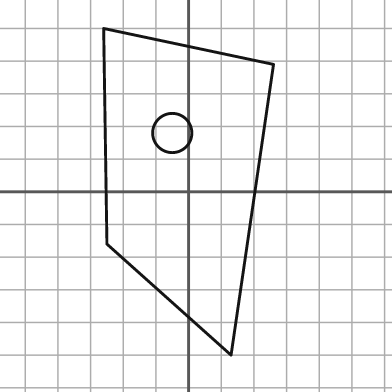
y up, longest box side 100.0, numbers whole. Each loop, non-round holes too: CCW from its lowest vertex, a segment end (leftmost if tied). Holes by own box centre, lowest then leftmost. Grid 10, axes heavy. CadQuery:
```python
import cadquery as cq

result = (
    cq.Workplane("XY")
    .moveTo(13.0, -50.0)
    .lineTo(26.0, 39.0)
    .lineTo(-26.0, 50.0)
    .lineTo(-25.0, -16.0)
    .close()
    .moveTo(-5.0, 18.0)
    .circle(6.0)
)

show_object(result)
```